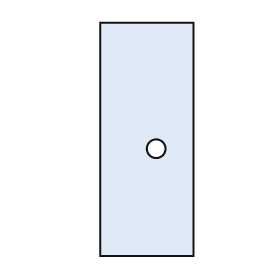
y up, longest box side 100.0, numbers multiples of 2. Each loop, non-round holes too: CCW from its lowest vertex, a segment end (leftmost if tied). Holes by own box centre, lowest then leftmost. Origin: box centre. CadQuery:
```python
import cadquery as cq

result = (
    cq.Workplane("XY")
    .moveTo(-20.0, -50.0)
    .lineTo(20.0, -50.0)
    .lineTo(20.0, 50.0)
    .lineTo(-20.0, 50.0)
    .close()
    .moveTo(4.0, -4.0)
    .circle(4.0)
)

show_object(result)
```